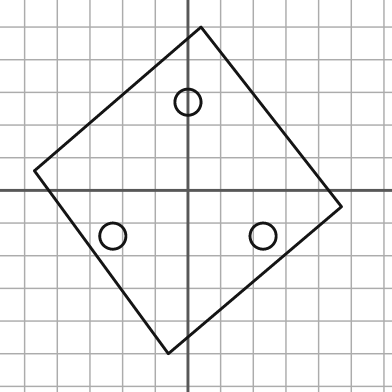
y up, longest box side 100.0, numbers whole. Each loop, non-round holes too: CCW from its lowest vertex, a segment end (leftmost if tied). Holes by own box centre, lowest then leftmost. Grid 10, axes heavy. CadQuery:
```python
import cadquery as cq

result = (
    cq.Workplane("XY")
    .moveTo(-6.0, -50.0)
    .lineTo(47.0, -5.0)
    .lineTo(4.0, 50.0)
    .lineTo(-47.0, 6.0)
    .close()
    .moveTo(-23.0, -14.0)
    .circle(4.0)
    .moveTo(23.0, -14.0)
    .circle(4.0)
    .moveTo(0.0, 27.0)
    .circle(4.0)
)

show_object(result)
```